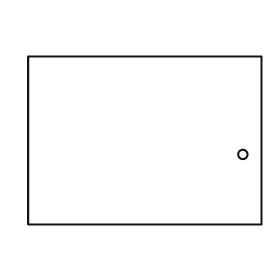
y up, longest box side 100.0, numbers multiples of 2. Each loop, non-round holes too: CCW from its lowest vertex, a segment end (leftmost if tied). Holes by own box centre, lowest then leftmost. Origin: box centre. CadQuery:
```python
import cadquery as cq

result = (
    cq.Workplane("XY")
    .moveTo(-50.0, -36.0)
    .lineTo(50.0, -36.0)
    .lineTo(50.0, 36.0)
    .lineTo(-50.0, 36.0)
    .close()
    .moveTo(42.0, -6.0)
    .circle(2.0)
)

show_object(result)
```